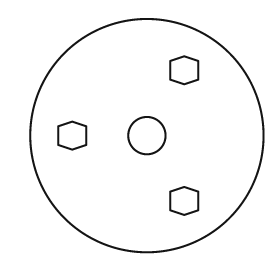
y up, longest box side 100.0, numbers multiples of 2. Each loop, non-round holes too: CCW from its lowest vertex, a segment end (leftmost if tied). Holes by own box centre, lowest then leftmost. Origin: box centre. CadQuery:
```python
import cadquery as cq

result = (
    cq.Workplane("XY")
    .moveTo(0.0, 0.0)
    .circle(50.0)
    .moveTo(16.0, -34.0)
    .lineTo(22.0, -32.0)
    .lineTo(22.0, -24.0)
    .lineTo(16.0, -22.0)
    .lineTo(10.0, -24.0)
    .lineTo(10.0, -32.0)
    .close()
    .moveTo(-32.0, -6.0)
    .lineTo(-26.0, -4.0)
    .lineTo(-26.0, 4.0)
    .lineTo(-32.0, 6.0)
    .lineTo(-38.0, 4.0)
    .lineTo(-38.0, -4.0)
    .close()
    .moveTo(0.0, 0.0)
    .circle(8.0)
    .moveTo(16.0, 22.0)
    .lineTo(22.0, 24.0)
    .lineTo(22.0, 32.0)
    .lineTo(16.0, 34.0)
    .lineTo(10.0, 32.0)
    .lineTo(10.0, 24.0)
    .close()
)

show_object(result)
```